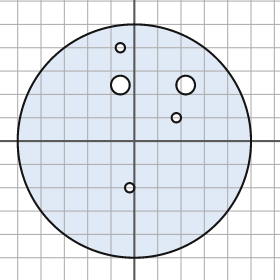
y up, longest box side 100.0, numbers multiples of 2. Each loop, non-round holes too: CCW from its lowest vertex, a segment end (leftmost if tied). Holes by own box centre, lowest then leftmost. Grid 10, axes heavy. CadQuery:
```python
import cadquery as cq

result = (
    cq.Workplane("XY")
    .moveTo(0.0, 0.0)
    .circle(50.0)
    .moveTo(-2.0, -20.0)
    .circle(2.0)
    .moveTo(18.0, 10.0)
    .circle(2.0)
    .moveTo(-6.0, 24.0)
    .circle(4.0)
    .moveTo(22.0, 24.0)
    .circle(4.0)
    .moveTo(-6.0, 40.0)
    .circle(2.0)
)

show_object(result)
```